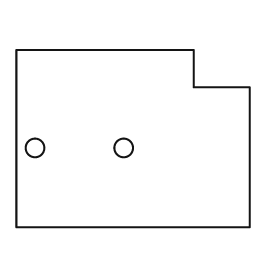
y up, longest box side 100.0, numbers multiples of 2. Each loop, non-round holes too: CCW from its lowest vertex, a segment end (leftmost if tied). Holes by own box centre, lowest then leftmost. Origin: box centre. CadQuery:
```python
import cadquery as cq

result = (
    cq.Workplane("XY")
    .moveTo(-50.0, -38.0)
    .lineTo(50.0, -38.0)
    .lineTo(50.0, 22.0)
    .lineTo(26.0, 22.0)
    .lineTo(26.0, 38.0)
    .lineTo(-50.0, 38.0)
    .close()
    .moveTo(-42.0, -4.0)
    .circle(4.0)
    .moveTo(-4.0, -4.0)
    .circle(4.0)
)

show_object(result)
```